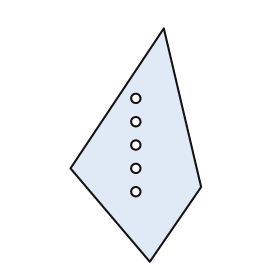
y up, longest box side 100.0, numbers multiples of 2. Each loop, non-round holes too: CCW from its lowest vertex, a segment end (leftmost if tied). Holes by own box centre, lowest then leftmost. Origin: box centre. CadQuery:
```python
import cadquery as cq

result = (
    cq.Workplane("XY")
    .moveTo(6.0, -50.0)
    .lineTo(28.0, -18.0)
    .lineTo(12.0, 50.0)
    .lineTo(-28.0, -10.0)
    .close()
    .moveTo(0.0, -20.0)
    .circle(2.0)
    .moveTo(0.0, -10.0)
    .circle(2.0)
    .moveTo(0.0, 0.0)
    .circle(2.0)
    .moveTo(0.0, 10.0)
    .circle(2.0)
    .moveTo(0.0, 20.0)
    .circle(2.0)
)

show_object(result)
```